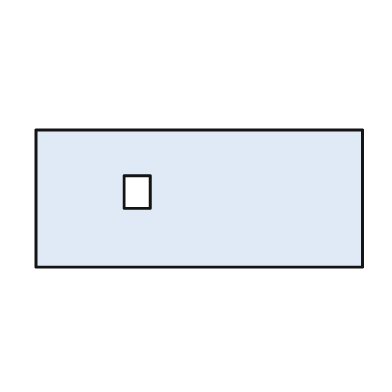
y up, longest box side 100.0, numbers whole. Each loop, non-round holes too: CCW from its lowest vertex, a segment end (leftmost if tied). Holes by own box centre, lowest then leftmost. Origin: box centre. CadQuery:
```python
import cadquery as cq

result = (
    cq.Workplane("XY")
    .moveTo(-50.0, -21.0)
    .lineTo(50.0, -21.0)
    .lineTo(50.0, 21.0)
    .lineTo(-50.0, 21.0)
    .close()
    .moveTo(-23.0, -3.0)
    .lineTo(-15.0, -3.0)
    .lineTo(-15.0, 7.0)
    .lineTo(-23.0, 7.0)
    .close()
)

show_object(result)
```